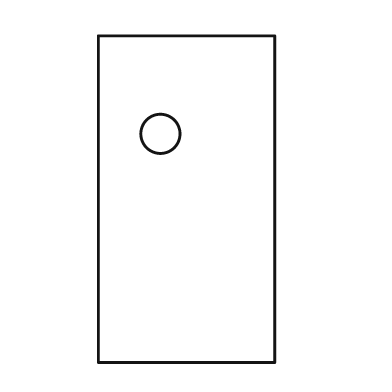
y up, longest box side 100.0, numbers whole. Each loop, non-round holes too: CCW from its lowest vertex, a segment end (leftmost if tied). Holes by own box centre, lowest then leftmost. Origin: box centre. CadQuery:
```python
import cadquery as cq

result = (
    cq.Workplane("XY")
    .moveTo(-27.0, -50.0)
    .lineTo(27.0, -50.0)
    .lineTo(27.0, 50.0)
    .lineTo(-27.0, 50.0)
    .close()
    .moveTo(-8.0, 20.0)
    .circle(6.0)
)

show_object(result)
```